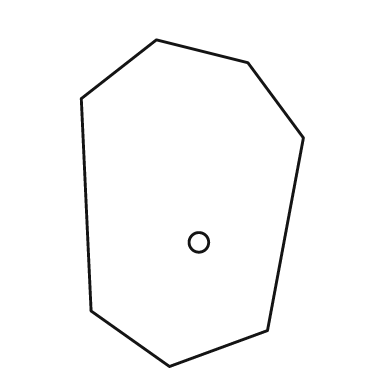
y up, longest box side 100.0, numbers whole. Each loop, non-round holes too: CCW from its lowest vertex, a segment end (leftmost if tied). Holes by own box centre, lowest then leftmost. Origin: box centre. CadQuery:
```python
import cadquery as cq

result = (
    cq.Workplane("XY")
    .moveTo(-7.0, -50.0)
    .lineTo(23.0, -39.0)
    .lineTo(34.0, 20.0)
    .lineTo(17.0, 43.0)
    .lineTo(-11.0, 50.0)
    .lineTo(-34.0, 32.0)
    .lineTo(-31.0, -33.0)
    .close()
    .moveTo(2.0, -12.0)
    .circle(3.0)
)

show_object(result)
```